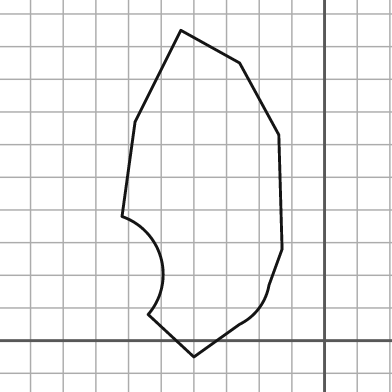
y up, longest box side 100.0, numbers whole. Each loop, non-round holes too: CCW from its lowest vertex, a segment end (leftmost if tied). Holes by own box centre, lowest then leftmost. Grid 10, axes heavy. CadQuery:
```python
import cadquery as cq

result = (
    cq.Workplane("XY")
    .moveTo(-40.0, -5.0)
    .lineTo(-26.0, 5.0)
    .threePointArc((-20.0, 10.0), (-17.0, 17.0))
    .lineTo(-13.0, 28.0)
    .lineTo(-14.0, 63.0)
    .lineTo(-26.0, 85.0)
    .lineTo(-44.0, 95.0)
    .lineTo(-58.0, 67.0)
    .lineTo(-62.0, 38.0)
    .threePointArc((-50.0, 25.0), (-54.0, 8.0))
    .close()
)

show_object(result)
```